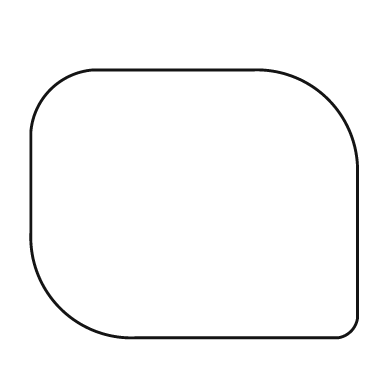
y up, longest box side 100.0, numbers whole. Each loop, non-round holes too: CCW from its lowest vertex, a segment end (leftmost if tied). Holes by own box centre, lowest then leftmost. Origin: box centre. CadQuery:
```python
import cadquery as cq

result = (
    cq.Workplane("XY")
    .moveTo(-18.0, -41.0)
    .lineTo(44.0, -41.0)
    .threePointArc((48.0, -39.0), (50.0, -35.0))
    .lineTo(50.0, 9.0)
    .threePointArc((41.0, 32.0), (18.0, 41.0))
    .lineTo(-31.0, 41.0)
    .threePointArc((-44.0, 35.0), (-50.0, 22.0))
    .lineTo(-50.0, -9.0)
    .threePointArc((-41.0, -32.0), (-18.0, -41.0))
    .close()
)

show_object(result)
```